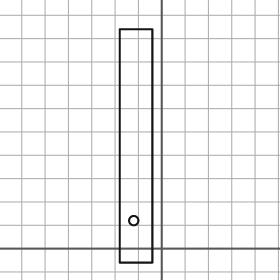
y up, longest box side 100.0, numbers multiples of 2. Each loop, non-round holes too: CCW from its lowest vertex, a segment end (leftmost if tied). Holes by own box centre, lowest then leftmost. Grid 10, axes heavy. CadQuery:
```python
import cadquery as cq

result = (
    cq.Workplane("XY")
    .moveTo(-18.0, -6.0)
    .lineTo(-4.0, -6.0)
    .lineTo(-4.0, 94.0)
    .lineTo(-18.0, 94.0)
    .close()
    .moveTo(-12.0, 12.0)
    .circle(2.0)
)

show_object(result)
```